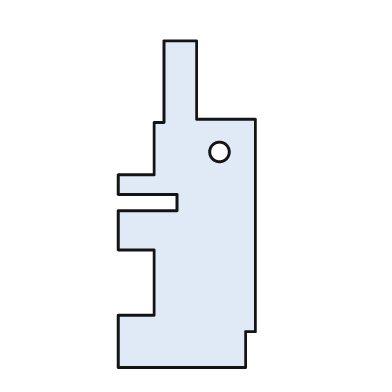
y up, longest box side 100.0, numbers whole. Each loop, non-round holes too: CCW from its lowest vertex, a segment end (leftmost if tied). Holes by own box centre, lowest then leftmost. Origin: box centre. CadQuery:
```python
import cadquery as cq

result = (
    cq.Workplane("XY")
    .moveTo(-21.0, -50.0)
    .lineTo(18.0, -50.0)
    .lineTo(18.0, -39.0)
    .lineTo(21.0, -39.0)
    .lineTo(21.0, 26.0)
    .lineTo(3.0, 26.0)
    .lineTo(3.0, 50.0)
    .lineTo(-7.0, 50.0)
    .lineTo(-7.0, 25.0)
    .lineTo(-10.0, 25.0)
    .lineTo(-10.0, 9.0)
    .lineTo(-21.0, 9.0)
    .lineTo(-21.0, 3.0)
    .lineTo(-3.0, 3.0)
    .lineTo(-3.0, -2.0)
    .lineTo(-21.0, -2.0)
    .lineTo(-21.0, -14.0)
    .lineTo(-10.0, -14.0)
    .lineTo(-10.0, -34.0)
    .lineTo(-21.0, -34.0)
    .close()
    .moveTo(10.0, 16.0)
    .circle(3.0)
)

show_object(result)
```